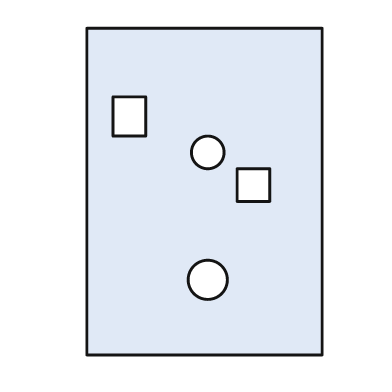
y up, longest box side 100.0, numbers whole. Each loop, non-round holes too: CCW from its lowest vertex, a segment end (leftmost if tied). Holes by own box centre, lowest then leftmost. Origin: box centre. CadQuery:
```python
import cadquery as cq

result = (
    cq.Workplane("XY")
    .moveTo(-36.0, -50.0)
    .lineTo(36.0, -50.0)
    .lineTo(36.0, 50.0)
    .lineTo(-36.0, 50.0)
    .close()
    .moveTo(1.0, -27.0)
    .circle(6.0)
    .moveTo(10.0, -3.0)
    .lineTo(20.0, -3.0)
    .lineTo(20.0, 7.0)
    .lineTo(10.0, 7.0)
    .close()
    .moveTo(1.0, 12.0)
    .circle(5.0)
    .moveTo(-28.0, 17.0)
    .lineTo(-18.0, 17.0)
    .lineTo(-18.0, 29.0)
    .lineTo(-28.0, 29.0)
    .close()
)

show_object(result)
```